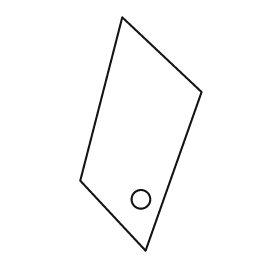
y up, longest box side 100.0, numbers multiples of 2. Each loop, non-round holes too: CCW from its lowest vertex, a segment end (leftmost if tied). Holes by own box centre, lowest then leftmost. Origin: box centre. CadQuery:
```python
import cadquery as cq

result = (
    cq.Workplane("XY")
    .moveTo(2.0, -50.0)
    .lineTo(26.0, 18.0)
    .lineTo(-8.0, 50.0)
    .lineTo(-26.0, -20.0)
    .close()
    .moveTo(0.0, -28.0)
    .circle(4.0)
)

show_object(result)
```